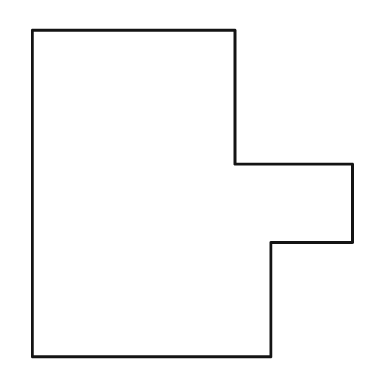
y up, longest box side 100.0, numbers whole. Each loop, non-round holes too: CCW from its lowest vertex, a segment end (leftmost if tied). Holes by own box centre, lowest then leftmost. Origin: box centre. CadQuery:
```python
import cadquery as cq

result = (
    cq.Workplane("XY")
    .moveTo(-49.0, -50.0)
    .lineTo(24.0, -50.0)
    .lineTo(24.0, -15.0)
    .lineTo(49.0, -15.0)
    .lineTo(49.0, 9.0)
    .lineTo(13.0, 9.0)
    .lineTo(13.0, 50.0)
    .lineTo(-49.0, 50.0)
    .close()
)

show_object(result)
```